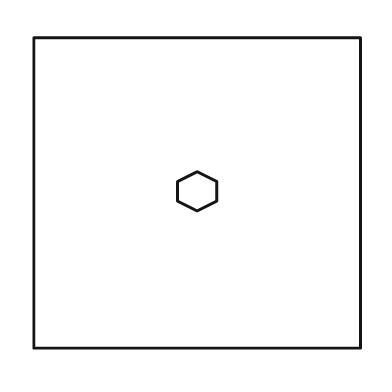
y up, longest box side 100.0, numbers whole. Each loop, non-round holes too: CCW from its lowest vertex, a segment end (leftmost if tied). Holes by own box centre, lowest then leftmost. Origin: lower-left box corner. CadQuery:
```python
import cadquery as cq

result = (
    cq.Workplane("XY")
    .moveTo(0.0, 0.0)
    .lineTo(100.0, 0.0)
    .lineTo(100.0, 95.0)
    .lineTo(0.0, 95.0)
    .close()
    .moveTo(50.0, 42.0)
    .lineTo(56.0, 45.0)
    .lineTo(56.0, 51.0)
    .lineTo(50.0, 54.0)
    .lineTo(44.0, 51.0)
    .lineTo(44.0, 45.0)
    .close()
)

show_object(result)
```